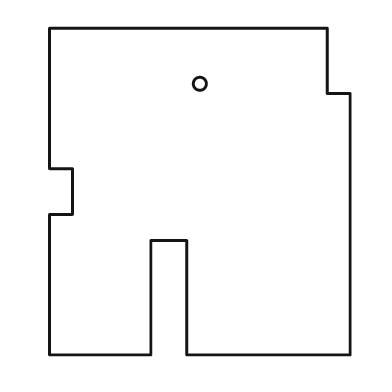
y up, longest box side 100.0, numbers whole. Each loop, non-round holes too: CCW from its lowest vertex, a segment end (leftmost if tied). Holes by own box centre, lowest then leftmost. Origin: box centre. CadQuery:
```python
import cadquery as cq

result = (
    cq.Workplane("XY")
    .moveTo(-46.0, -50.0)
    .lineTo(-15.0, -50.0)
    .lineTo(-15.0, -15.0)
    .lineTo(-4.0, -15.0)
    .lineTo(-4.0, -50.0)
    .lineTo(46.0, -50.0)
    .lineTo(46.0, 30.0)
    .lineTo(39.0, 30.0)
    .lineTo(39.0, 50.0)
    .lineTo(-46.0, 50.0)
    .lineTo(-46.0, 7.0)
    .lineTo(-39.0, 7.0)
    .lineTo(-39.0, -7.0)
    .lineTo(-46.0, -7.0)
    .close()
    .moveTo(0.0, 33.0)
    .circle(2.0)
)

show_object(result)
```